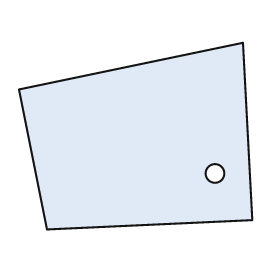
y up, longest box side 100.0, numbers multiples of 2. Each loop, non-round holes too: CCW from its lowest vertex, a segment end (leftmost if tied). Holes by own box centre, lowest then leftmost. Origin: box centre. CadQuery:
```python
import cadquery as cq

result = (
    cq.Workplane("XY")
    .moveTo(-38.0, -40.0)
    .lineTo(50.0, -36.0)
    .lineTo(46.0, 40.0)
    .lineTo(-50.0, 20.0)
    .close()
    .moveTo(34.0, -16.0)
    .circle(4.0)
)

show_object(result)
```